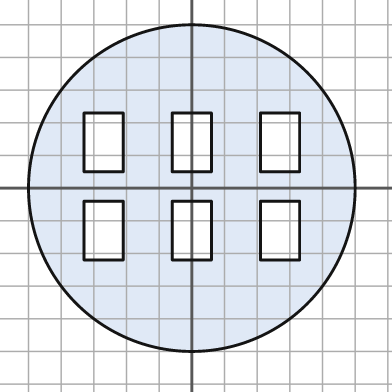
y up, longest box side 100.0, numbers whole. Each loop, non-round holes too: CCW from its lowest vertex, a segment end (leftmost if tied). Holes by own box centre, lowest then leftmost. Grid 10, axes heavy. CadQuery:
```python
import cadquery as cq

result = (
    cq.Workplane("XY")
    .moveTo(0.0, 0.0)
    .circle(50.0)
    .moveTo(-33.0, -22.0)
    .lineTo(-21.0, -22.0)
    .lineTo(-21.0, -4.0)
    .lineTo(-33.0, -4.0)
    .close()
    .moveTo(-6.0, -22.0)
    .lineTo(6.0, -22.0)
    .lineTo(6.0, -4.0)
    .lineTo(-6.0, -4.0)
    .close()
    .moveTo(21.0, -22.0)
    .lineTo(33.0, -22.0)
    .lineTo(33.0, -4.0)
    .lineTo(21.0, -4.0)
    .close()
    .moveTo(-33.0, 5.0)
    .lineTo(-21.0, 5.0)
    .lineTo(-21.0, 23.0)
    .lineTo(-33.0, 23.0)
    .close()
    .moveTo(-6.0, 5.0)
    .lineTo(6.0, 5.0)
    .lineTo(6.0, 23.0)
    .lineTo(-6.0, 23.0)
    .close()
    .moveTo(21.0, 5.0)
    .lineTo(33.0, 5.0)
    .lineTo(33.0, 23.0)
    .lineTo(21.0, 23.0)
    .close()
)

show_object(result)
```